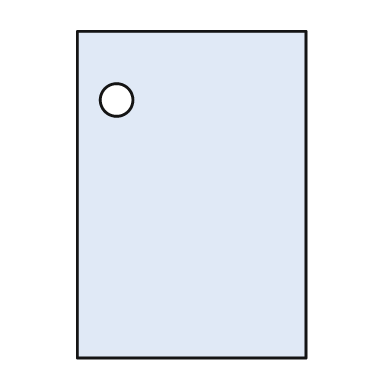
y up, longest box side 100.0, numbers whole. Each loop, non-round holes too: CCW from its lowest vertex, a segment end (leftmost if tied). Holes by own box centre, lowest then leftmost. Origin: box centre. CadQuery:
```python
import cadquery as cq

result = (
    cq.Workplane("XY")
    .moveTo(-35.0, -50.0)
    .lineTo(35.0, -50.0)
    .lineTo(35.0, 50.0)
    .lineTo(-35.0, 50.0)
    .close()
    .moveTo(-23.0, 29.0)
    .circle(5.0)
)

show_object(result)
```